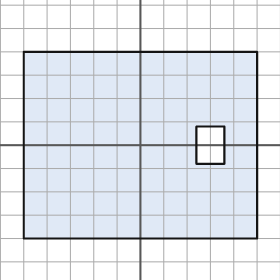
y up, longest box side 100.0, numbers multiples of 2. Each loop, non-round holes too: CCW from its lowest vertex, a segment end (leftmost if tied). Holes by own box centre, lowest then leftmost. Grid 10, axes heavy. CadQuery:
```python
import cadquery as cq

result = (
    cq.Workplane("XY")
    .moveTo(-50.0, -40.0)
    .lineTo(50.0, -40.0)
    .lineTo(50.0, 40.0)
    .lineTo(-50.0, 40.0)
    .close()
    .moveTo(24.0, -8.0)
    .lineTo(36.0, -8.0)
    .lineTo(36.0, 8.0)
    .lineTo(24.0, 8.0)
    .close()
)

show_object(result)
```